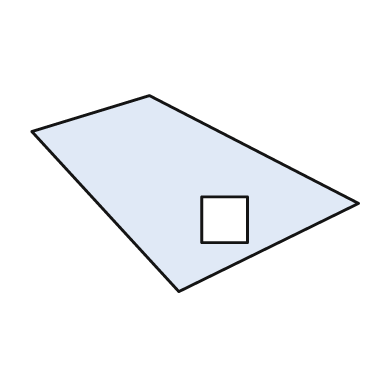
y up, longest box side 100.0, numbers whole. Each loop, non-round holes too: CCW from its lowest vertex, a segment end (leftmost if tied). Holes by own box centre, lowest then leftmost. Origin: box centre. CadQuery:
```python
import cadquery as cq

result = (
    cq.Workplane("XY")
    .moveTo(-5.0, -30.0)
    .lineTo(50.0, -3.0)
    .lineTo(-14.0, 30.0)
    .lineTo(-50.0, 19.0)
    .close()
    .moveTo(2.0, -15.0)
    .lineTo(16.0, -15.0)
    .lineTo(16.0, -1.0)
    .lineTo(2.0, -1.0)
    .close()
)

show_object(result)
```